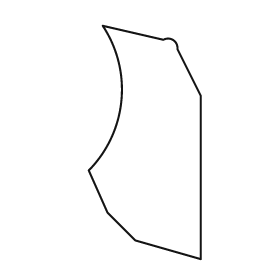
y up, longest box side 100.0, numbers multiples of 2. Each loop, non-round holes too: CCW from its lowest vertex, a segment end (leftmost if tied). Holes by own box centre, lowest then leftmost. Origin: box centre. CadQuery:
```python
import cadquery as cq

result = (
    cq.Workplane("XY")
    .moveTo(24.0, -50.0)
    .lineTo(24.0, 20.0)
    .lineTo(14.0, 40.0)
    .threePointArc((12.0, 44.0), (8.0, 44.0))
    .lineTo(-18.0, 50.0)
    .threePointArc((-10.0, 18.0), (-24.0, -12.0))
    .lineTo(-16.0, -30.0)
    .lineTo(-4.0, -42.0)
    .close()
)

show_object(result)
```